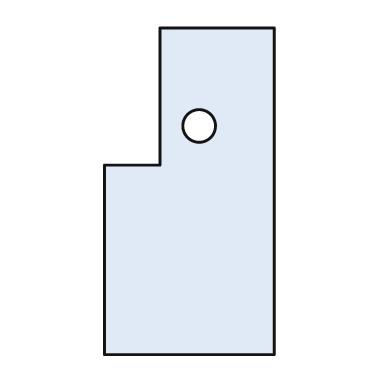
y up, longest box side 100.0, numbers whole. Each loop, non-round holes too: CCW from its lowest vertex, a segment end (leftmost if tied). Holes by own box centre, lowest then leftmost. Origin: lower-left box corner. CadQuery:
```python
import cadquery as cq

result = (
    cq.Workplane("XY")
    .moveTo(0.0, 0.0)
    .lineTo(52.0, 0.0)
    .lineTo(52.0, 100.0)
    .lineTo(17.0, 100.0)
    .lineTo(17.0, 58.0)
    .lineTo(0.0, 58.0)
    .close()
    .moveTo(29.0, 70.0)
    .circle(5.0)
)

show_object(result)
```